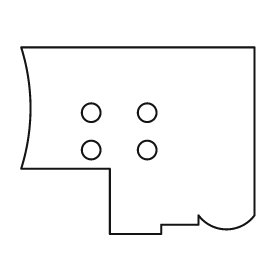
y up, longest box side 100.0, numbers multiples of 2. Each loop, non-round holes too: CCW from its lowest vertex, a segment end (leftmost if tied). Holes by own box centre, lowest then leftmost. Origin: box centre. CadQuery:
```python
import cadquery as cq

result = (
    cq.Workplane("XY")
    .moveTo(-12.0, -40.0)
    .lineTo(10.0, -40.0)
    .lineTo(10.0, -36.0)
    .lineTo(26.0, -36.0)
    .lineTo(26.0, -32.0)
    .threePointArc((38.0, -38.0), (50.0, -32.0))
    .lineTo(50.0, 40.0)
    .lineTo(-50.0, 40.0)
    .threePointArc((-46.0, 14.0), (-50.0, -12.0))
    .lineTo(-12.0, -12.0)
    .close()
    .moveTo(-20.0, -4.0)
    .circle(4.0)
    .moveTo(4.0, -4.0)
    .circle(4.0)
    .moveTo(-20.0, 12.0)
    .circle(4.0)
    .moveTo(4.0, 12.0)
    .circle(4.0)
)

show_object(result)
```